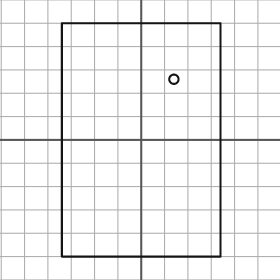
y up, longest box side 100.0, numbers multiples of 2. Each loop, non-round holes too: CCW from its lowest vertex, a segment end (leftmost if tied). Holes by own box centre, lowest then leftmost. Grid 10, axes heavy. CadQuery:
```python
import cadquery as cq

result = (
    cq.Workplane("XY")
    .moveTo(-34.0, -50.0)
    .lineTo(34.0, -50.0)
    .lineTo(34.0, 50.0)
    .lineTo(-34.0, 50.0)
    .close()
    .moveTo(14.0, 26.0)
    .circle(2.0)
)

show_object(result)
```